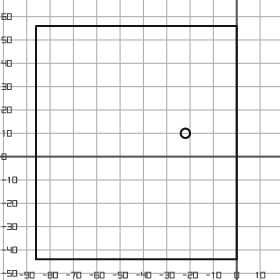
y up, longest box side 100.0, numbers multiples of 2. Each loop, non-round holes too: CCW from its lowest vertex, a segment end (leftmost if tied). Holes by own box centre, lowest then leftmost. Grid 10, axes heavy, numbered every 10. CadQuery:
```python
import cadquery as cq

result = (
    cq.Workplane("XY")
    .moveTo(-86.0, -44.0)
    .lineTo(0.0, -44.0)
    .lineTo(0.0, 56.0)
    .lineTo(-86.0, 56.0)
    .close()
    .moveTo(-22.0, 10.0)
    .circle(2.0)
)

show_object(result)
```